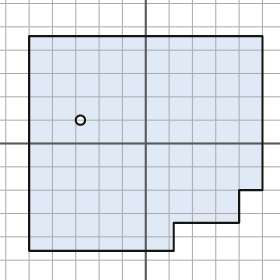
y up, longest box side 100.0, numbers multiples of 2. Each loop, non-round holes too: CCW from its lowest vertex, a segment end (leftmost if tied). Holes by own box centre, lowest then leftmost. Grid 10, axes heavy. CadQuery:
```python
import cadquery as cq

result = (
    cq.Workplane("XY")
    .moveTo(-50.0, -46.0)
    .lineTo(12.0, -46.0)
    .lineTo(12.0, -34.0)
    .lineTo(40.0, -34.0)
    .lineTo(40.0, -20.0)
    .lineTo(50.0, -20.0)
    .lineTo(50.0, 46.0)
    .lineTo(-50.0, 46.0)
    .close()
    .moveTo(-28.0, 10.0)
    .circle(2.0)
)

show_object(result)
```